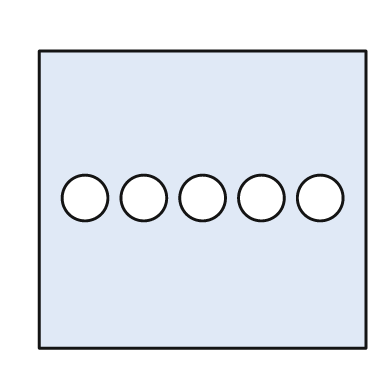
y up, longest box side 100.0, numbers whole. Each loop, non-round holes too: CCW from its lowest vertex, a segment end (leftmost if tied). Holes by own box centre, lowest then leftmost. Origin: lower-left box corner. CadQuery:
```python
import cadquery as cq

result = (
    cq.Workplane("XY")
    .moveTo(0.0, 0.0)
    .lineTo(100.0, 0.0)
    .lineTo(100.0, 91.0)
    .lineTo(0.0, 91.0)
    .close()
    .moveTo(14.0, 46.0)
    .circle(7.0)
    .moveTo(32.0, 46.0)
    .circle(7.0)
    .moveTo(50.0, 46.0)
    .circle(7.0)
    .moveTo(68.0, 46.0)
    .circle(7.0)
    .moveTo(86.0, 46.0)
    .circle(7.0)
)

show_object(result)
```